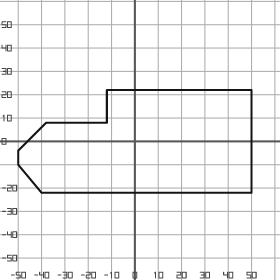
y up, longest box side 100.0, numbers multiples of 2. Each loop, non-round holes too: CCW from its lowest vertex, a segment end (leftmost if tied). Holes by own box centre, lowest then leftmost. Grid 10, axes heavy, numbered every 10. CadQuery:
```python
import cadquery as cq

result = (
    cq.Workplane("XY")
    .moveTo(-40.0, -22.0)
    .lineTo(50.0, -22.0)
    .lineTo(50.0, 22.0)
    .lineTo(-12.0, 22.0)
    .lineTo(-12.0, 8.0)
    .lineTo(-38.0, 8.0)
    .lineTo(-50.0, -4.0)
    .lineTo(-50.0, -10.0)
    .close()
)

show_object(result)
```